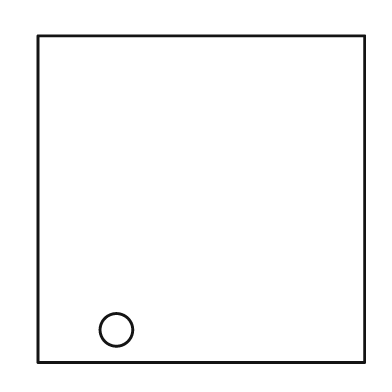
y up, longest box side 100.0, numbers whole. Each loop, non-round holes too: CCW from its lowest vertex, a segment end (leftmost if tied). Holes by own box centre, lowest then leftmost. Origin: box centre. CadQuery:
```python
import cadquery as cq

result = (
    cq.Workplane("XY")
    .moveTo(-50.0, -50.0)
    .lineTo(50.0, -50.0)
    .lineTo(50.0, 50.0)
    .lineTo(-50.0, 50.0)
    .close()
    .moveTo(-26.0, -40.0)
    .circle(5.0)
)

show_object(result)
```